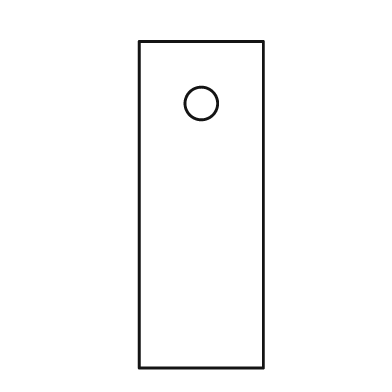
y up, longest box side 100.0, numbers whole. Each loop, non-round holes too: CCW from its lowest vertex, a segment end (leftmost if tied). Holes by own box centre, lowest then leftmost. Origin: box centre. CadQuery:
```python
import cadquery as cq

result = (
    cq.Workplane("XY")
    .moveTo(-19.0, -50.0)
    .lineTo(19.0, -50.0)
    .lineTo(19.0, 50.0)
    .lineTo(-19.0, 50.0)
    .close()
    .moveTo(0.0, 31.0)
    .circle(5.0)
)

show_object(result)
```